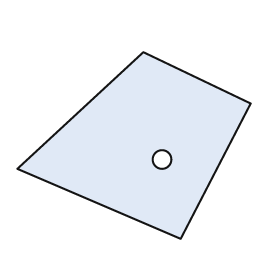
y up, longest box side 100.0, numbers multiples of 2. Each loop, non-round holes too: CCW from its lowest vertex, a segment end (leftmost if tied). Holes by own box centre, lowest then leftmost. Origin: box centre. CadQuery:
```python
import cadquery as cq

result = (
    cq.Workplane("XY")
    .moveTo(20.0, -40.0)
    .lineTo(50.0, 18.0)
    .lineTo(4.0, 40.0)
    .lineTo(-50.0, -10.0)
    .close()
    .moveTo(12.0, -6.0)
    .circle(4.0)
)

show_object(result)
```